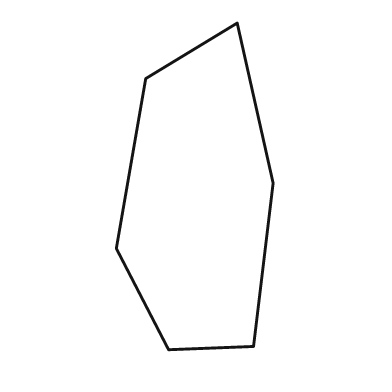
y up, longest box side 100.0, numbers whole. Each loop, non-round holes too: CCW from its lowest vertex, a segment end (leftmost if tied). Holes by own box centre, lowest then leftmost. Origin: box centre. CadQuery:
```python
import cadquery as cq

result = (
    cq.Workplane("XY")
    .moveTo(-8.0, -50.0)
    .lineTo(18.0, -49.0)
    .lineTo(24.0, 1.0)
    .lineTo(13.0, 50.0)
    .lineTo(-15.0, 33.0)
    .lineTo(-24.0, -19.0)
    .close()
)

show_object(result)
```